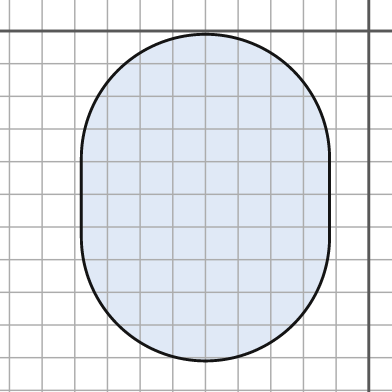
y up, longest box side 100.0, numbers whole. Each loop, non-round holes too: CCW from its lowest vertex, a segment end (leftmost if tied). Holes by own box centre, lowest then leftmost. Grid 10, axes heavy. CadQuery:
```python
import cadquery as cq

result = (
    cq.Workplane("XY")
    .moveTo(-88.0, -63.0)
    .threePointArc((-50.0, -101.0), (-12.0, -63.0))
    .lineTo(-12.0, -39.0)
    .threePointArc((-50.0, -1.0), (-88.0, -39.0))
    .close()
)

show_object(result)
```